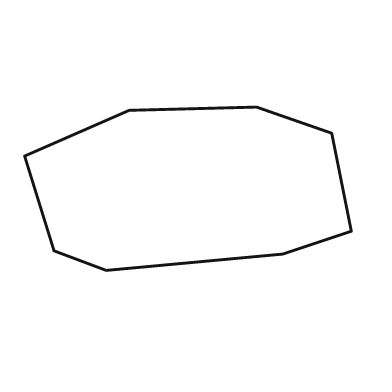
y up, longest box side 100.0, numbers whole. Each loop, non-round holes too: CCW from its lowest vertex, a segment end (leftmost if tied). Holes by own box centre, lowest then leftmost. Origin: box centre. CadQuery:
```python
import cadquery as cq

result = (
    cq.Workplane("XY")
    .moveTo(-25.0, -25.0)
    .lineTo(29.0, -20.0)
    .lineTo(50.0, -13.0)
    .lineTo(44.0, 17.0)
    .lineTo(21.0, 25.0)
    .lineTo(-18.0, 24.0)
    .lineTo(-50.0, 10.0)
    .lineTo(-41.0, -19.0)
    .close()
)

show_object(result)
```